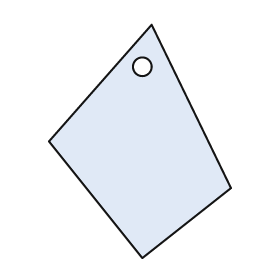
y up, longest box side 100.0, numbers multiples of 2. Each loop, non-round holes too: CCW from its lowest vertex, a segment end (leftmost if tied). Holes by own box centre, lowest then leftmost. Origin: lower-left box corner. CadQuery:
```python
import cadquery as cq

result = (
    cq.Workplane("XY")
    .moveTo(40.0, 0.0)
    .lineTo(78.0, 30.0)
    .lineTo(44.0, 100.0)
    .lineTo(0.0, 50.0)
    .close()
    .moveTo(40.0, 82.0)
    .circle(4.0)
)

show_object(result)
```